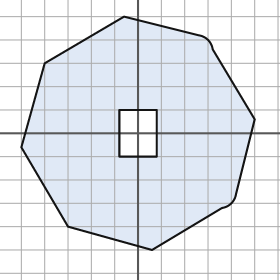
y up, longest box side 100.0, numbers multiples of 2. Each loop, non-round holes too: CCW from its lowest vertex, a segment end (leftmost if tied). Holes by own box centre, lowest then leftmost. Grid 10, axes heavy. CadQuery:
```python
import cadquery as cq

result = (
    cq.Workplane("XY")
    .moveTo(6.0, -50.0)
    .lineTo(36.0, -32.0)
    .threePointArc((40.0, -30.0), (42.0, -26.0))
    .lineTo(50.0, 6.0)
    .lineTo(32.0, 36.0)
    .threePointArc((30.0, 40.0), (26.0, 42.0))
    .lineTo(-6.0, 50.0)
    .lineTo(-40.0, 30.0)
    .lineTo(-50.0, -6.0)
    .lineTo(-30.0, -40.0)
    .close()
    .moveTo(-8.0, -10.0)
    .lineTo(8.0, -10.0)
    .lineTo(8.0, 10.0)
    .lineTo(-8.0, 10.0)
    .close()
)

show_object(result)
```